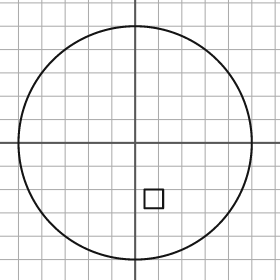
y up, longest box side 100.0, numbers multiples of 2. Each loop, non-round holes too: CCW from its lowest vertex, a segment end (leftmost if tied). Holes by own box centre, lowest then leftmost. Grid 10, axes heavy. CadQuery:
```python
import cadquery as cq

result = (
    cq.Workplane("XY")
    .moveTo(0.0, 0.0)
    .circle(50.0)
    .moveTo(4.0, -28.0)
    .lineTo(12.0, -28.0)
    .lineTo(12.0, -20.0)
    .lineTo(4.0, -20.0)
    .close()
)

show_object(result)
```